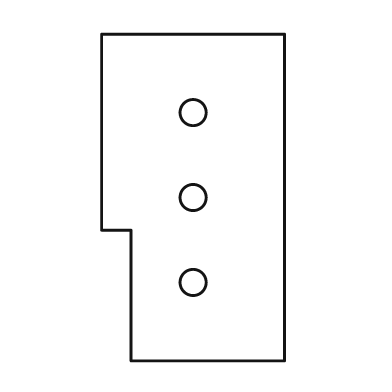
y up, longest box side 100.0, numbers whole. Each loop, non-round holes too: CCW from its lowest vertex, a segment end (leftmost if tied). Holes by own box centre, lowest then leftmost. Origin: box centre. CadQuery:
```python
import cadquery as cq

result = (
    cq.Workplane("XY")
    .moveTo(-19.0, -50.0)
    .lineTo(28.0, -50.0)
    .lineTo(28.0, 50.0)
    .lineTo(-28.0, 50.0)
    .lineTo(-28.0, -10.0)
    .lineTo(-19.0, -10.0)
    .close()
    .moveTo(0.0, -26.0)
    .circle(4.0)
    .moveTo(0.0, 0.0)
    .circle(4.0)
    .moveTo(0.0, 26.0)
    .circle(4.0)
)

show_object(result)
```